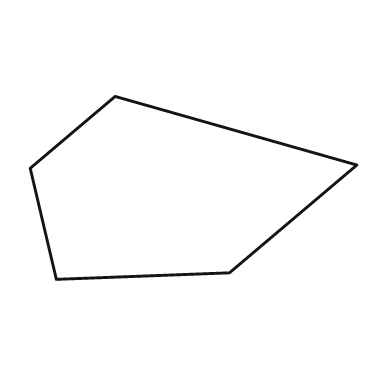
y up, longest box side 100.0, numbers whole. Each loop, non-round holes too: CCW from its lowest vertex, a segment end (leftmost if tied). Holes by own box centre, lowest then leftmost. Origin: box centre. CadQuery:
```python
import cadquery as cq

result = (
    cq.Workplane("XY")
    .moveTo(-42.0, -28.0)
    .lineTo(11.0, -26.0)
    .lineTo(50.0, 7.0)
    .lineTo(-24.0, 28.0)
    .lineTo(-50.0, 6.0)
    .close()
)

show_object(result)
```